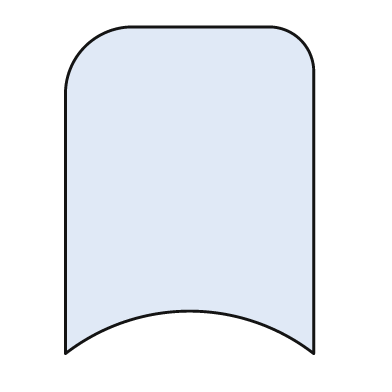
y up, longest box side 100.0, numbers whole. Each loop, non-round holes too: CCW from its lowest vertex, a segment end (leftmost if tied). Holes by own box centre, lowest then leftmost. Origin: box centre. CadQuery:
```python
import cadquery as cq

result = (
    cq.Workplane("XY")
    .moveTo(-38.0, -50.0)
    .threePointArc((0.0, -37.0), (38.0, -50.0))
    .lineTo(38.0, 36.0)
    .threePointArc((34.0, 46.0), (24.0, 50.0))
    .lineTo(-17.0, 50.0)
    .threePointArc((-32.0, 44.0), (-38.0, 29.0))
    .close()
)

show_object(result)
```